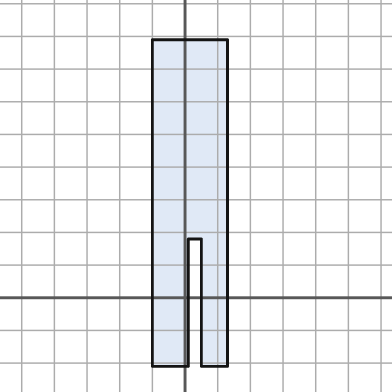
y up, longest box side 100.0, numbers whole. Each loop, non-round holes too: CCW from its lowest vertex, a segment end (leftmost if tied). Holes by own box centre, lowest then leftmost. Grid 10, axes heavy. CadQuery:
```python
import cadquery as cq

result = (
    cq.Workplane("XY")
    .moveTo(-10.0, -21.0)
    .lineTo(1.0, -21.0)
    .lineTo(1.0, 18.0)
    .lineTo(5.0, 18.0)
    .lineTo(5.0, -21.0)
    .lineTo(13.0, -21.0)
    .lineTo(13.0, 79.0)
    .lineTo(-10.0, 79.0)
    .close()
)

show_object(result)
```